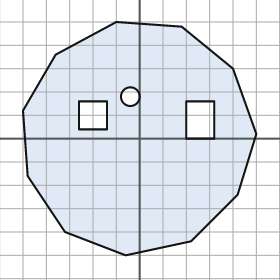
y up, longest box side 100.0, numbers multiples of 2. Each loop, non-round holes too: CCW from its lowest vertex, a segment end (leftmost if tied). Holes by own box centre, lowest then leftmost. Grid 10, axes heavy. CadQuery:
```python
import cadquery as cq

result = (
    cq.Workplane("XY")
    .moveTo(-6.0, -50.0)
    .lineTo(22.0, -44.0)
    .lineTo(42.0, -24.0)
    .lineTo(50.0, 2.0)
    .lineTo(40.0, 30.0)
    .lineTo(18.0, 48.0)
    .lineTo(-10.0, 50.0)
    .lineTo(-36.0, 36.0)
    .lineTo(-50.0, 12.0)
    .lineTo(-48.0, -16.0)
    .lineTo(-32.0, -40.0)
    .close()
    .moveTo(20.0, 0.0)
    .lineTo(32.0, 0.0)
    .lineTo(32.0, 16.0)
    .lineTo(20.0, 16.0)
    .close()
    .moveTo(-26.0, 4.0)
    .lineTo(-14.0, 4.0)
    .lineTo(-14.0, 16.0)
    .lineTo(-26.0, 16.0)
    .close()
    .moveTo(-4.0, 18.0)
    .circle(4.0)
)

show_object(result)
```